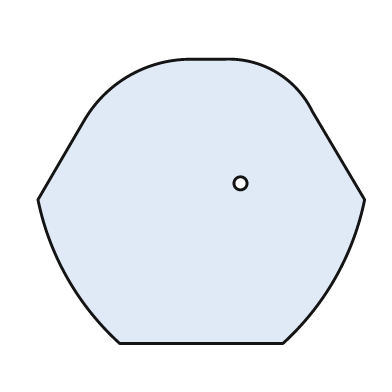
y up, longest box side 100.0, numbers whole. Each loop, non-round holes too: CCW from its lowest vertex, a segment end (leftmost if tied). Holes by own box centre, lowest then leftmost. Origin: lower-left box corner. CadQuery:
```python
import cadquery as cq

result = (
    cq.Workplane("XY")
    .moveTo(25.0, 0.0)
    .lineTo(75.0, 0.0)
    .threePointArc((91.0, 20.0), (100.0, 44.0))
    .lineTo(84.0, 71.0)
    .threePointArc((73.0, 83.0), (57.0, 87.0))
    .lineTo(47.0, 87.0)
    .threePointArc((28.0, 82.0), (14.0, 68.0))
    .lineTo(0.0, 44.0)
    .threePointArc((9.0, 20.0), (25.0, 0.0))
    .close()
    .moveTo(62.0, 49.0)
    .circle(2.0)
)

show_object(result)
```